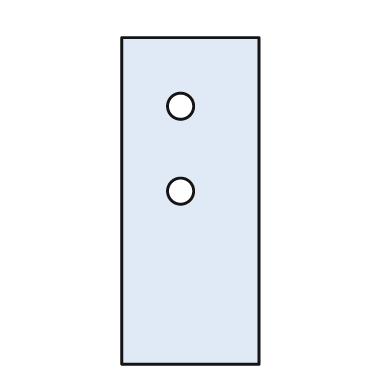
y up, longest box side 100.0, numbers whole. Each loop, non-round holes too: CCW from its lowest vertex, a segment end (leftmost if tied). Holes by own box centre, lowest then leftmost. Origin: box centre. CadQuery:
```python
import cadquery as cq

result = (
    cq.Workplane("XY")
    .moveTo(-21.0, -50.0)
    .lineTo(21.0, -50.0)
    .lineTo(21.0, 50.0)
    .lineTo(-21.0, 50.0)
    .close()
    .moveTo(-3.0, 3.0)
    .circle(4.0)
    .moveTo(-3.0, 29.0)
    .circle(4.0)
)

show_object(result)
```